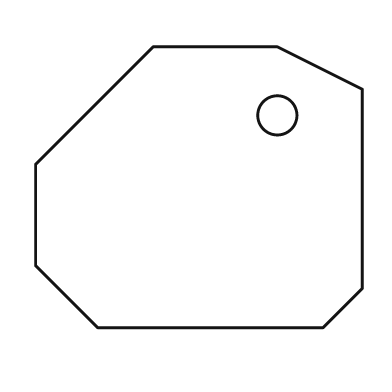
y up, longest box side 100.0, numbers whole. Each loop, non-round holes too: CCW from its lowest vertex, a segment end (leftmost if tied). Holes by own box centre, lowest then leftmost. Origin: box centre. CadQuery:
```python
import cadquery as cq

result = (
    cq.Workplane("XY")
    .moveTo(-31.0, -43.0)
    .lineTo(38.0, -43.0)
    .lineTo(50.0, -31.0)
    .lineTo(50.0, 30.0)
    .lineTo(24.0, 43.0)
    .lineTo(-14.0, 43.0)
    .lineTo(-50.0, 7.0)
    .lineTo(-50.0, -24.0)
    .close()
    .moveTo(24.0, 22.0)
    .circle(6.0)
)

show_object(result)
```